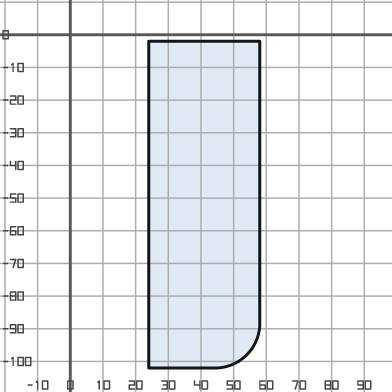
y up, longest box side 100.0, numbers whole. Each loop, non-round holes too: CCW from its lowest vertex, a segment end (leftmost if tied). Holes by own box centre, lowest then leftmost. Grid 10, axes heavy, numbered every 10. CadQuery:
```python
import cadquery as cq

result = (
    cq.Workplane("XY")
    .moveTo(24.0, -102.0)
    .lineTo(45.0, -102.0)
    .threePointArc((54.0, -98.0), (58.0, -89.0))
    .lineTo(58.0, -2.0)
    .lineTo(24.0, -2.0)
    .close()
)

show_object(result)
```